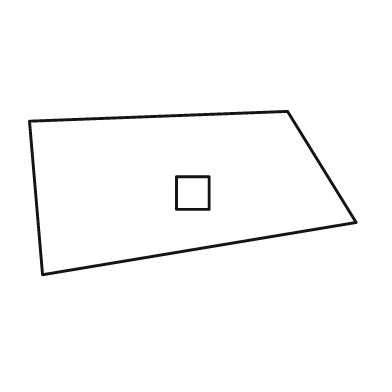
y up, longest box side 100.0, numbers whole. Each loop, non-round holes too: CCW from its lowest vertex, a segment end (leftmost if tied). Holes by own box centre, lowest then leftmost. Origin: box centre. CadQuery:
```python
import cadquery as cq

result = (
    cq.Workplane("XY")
    .moveTo(-46.0, -25.0)
    .lineTo(50.0, -9.0)
    .lineTo(29.0, 25.0)
    .lineTo(-50.0, 22.0)
    .close()
    .moveTo(-5.0, -5.0)
    .lineTo(5.0, -5.0)
    .lineTo(5.0, 5.0)
    .lineTo(-5.0, 5.0)
    .close()
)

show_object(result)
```